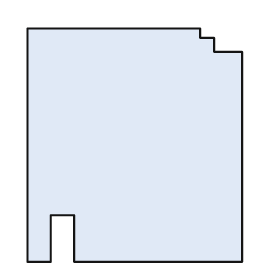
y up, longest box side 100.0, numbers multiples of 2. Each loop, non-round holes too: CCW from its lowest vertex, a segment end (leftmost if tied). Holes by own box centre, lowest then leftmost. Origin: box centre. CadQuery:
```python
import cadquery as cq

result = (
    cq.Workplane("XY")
    .moveTo(-46.0, -50.0)
    .lineTo(-36.0, -50.0)
    .lineTo(-36.0, -30.0)
    .lineTo(-26.0, -30.0)
    .lineTo(-26.0, -50.0)
    .lineTo(46.0, -50.0)
    .lineTo(46.0, 40.0)
    .lineTo(34.0, 40.0)
    .lineTo(34.0, 46.0)
    .lineTo(28.0, 46.0)
    .lineTo(28.0, 50.0)
    .lineTo(-46.0, 50.0)
    .close()
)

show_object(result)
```